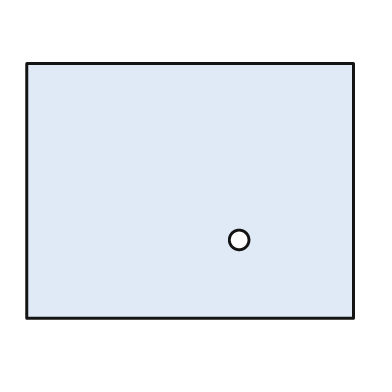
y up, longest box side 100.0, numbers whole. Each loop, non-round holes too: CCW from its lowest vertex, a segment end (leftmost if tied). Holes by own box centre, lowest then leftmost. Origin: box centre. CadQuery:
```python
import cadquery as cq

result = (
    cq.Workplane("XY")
    .moveTo(-50.0, -39.0)
    .lineTo(50.0, -39.0)
    .lineTo(50.0, 39.0)
    .lineTo(-50.0, 39.0)
    .close()
    .moveTo(15.0, -15.0)
    .circle(3.0)
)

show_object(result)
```